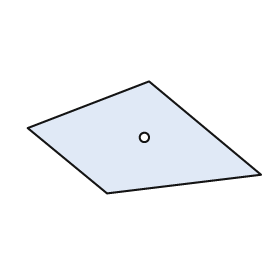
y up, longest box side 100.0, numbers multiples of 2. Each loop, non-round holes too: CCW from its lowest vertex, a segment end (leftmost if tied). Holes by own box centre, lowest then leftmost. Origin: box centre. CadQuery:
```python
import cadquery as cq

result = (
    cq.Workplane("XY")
    .moveTo(-16.0, -24.0)
    .lineTo(50.0, -16.0)
    .lineTo(2.0, 24.0)
    .lineTo(-50.0, 4.0)
    .close()
    .moveTo(0.0, 0.0)
    .circle(2.0)
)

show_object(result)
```